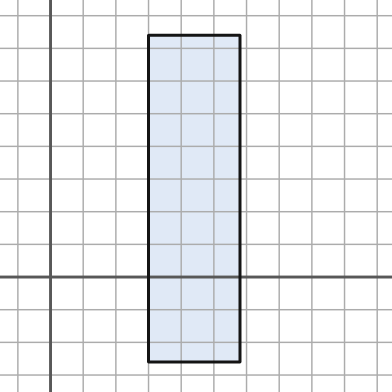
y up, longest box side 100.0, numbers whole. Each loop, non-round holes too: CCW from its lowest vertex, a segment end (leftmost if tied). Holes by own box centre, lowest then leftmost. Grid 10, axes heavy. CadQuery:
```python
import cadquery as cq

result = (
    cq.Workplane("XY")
    .moveTo(30.0, -26.0)
    .lineTo(58.0, -26.0)
    .lineTo(58.0, 74.0)
    .lineTo(30.0, 74.0)
    .close()
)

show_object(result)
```